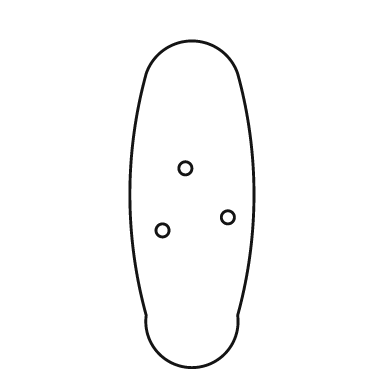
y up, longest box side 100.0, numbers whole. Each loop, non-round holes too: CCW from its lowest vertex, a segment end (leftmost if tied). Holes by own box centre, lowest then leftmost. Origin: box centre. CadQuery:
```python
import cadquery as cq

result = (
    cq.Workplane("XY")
    .moveTo(-14.0, -34.0)
    .threePointArc((0.0, -50.0), (14.0, -34.0))
    .threePointArc((19.0, 3.0), (14.0, 40.0))
    .threePointArc((0.0, 50.0), (-14.0, 40.0))
    .threePointArc((-19.0, 3.0), (-14.0, -34.0))
    .close()
    .moveTo(-9.0, -8.0)
    .circle(2.0)
    .moveTo(11.0, -4.0)
    .circle(2.0)
    .moveTo(-2.0, 11.0)
    .circle(2.0)
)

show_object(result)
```